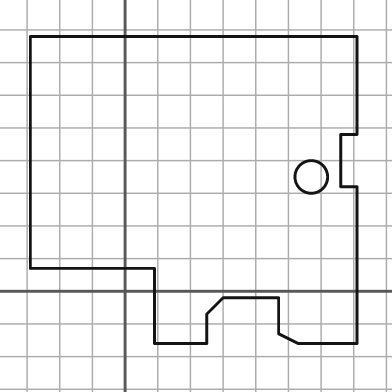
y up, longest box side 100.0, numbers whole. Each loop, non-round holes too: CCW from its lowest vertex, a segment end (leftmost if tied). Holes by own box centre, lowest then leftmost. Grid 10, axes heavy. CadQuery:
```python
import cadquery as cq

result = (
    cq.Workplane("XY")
    .moveTo(9.0, -16.0)
    .lineTo(25.0, -16.0)
    .lineTo(25.0, -7.0)
    .lineTo(30.0, -2.0)
    .lineTo(47.0, -2.0)
    .lineTo(47.0, -13.0)
    .lineTo(53.0, -16.0)
    .lineTo(71.0, -16.0)
    .lineTo(71.0, 32.0)
    .lineTo(66.0, 32.0)
    .lineTo(66.0, 48.0)
    .lineTo(71.0, 48.0)
    .lineTo(71.0, 78.0)
    .lineTo(-29.0, 78.0)
    .lineTo(-29.0, 7.0)
    .lineTo(9.0, 7.0)
    .close()
    .moveTo(57.0, 35.0)
    .circle(5.0)
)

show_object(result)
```